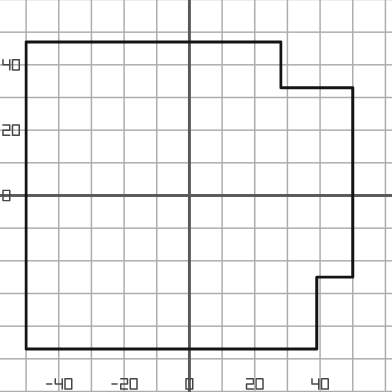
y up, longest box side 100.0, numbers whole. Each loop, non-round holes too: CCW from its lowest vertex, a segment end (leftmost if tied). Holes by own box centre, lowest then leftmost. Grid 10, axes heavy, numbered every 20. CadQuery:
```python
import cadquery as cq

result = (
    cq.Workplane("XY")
    .moveTo(-50.0, -47.0)
    .lineTo(39.0, -47.0)
    .lineTo(39.0, -25.0)
    .lineTo(50.0, -25.0)
    .lineTo(50.0, 33.0)
    .lineTo(28.0, 33.0)
    .lineTo(28.0, 47.0)
    .lineTo(-50.0, 47.0)
    .close()
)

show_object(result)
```